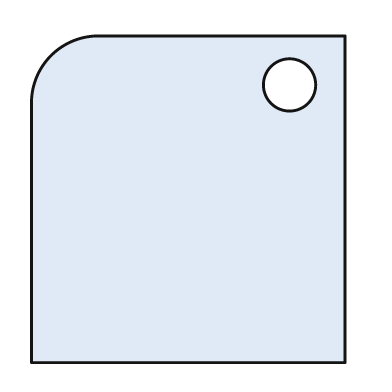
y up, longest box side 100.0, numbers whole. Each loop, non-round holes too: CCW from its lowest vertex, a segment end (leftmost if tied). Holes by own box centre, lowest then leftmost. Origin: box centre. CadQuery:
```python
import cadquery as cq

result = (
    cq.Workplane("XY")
    .moveTo(-48.0, -50.0)
    .lineTo(48.0, -50.0)
    .lineTo(48.0, 50.0)
    .lineTo(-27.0, 50.0)
    .threePointArc((-42.0, 44.0), (-48.0, 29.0))
    .close()
    .moveTo(31.0, 35.0)
    .circle(8.0)
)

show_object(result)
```